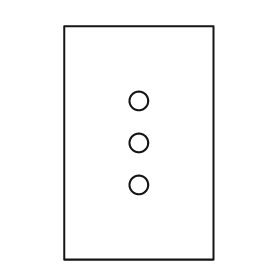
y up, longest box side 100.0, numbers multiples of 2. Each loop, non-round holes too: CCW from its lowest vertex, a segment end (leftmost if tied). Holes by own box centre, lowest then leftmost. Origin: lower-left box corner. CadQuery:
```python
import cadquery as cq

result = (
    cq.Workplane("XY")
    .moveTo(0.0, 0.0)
    .lineTo(64.0, 0.0)
    .lineTo(64.0, 100.0)
    .lineTo(0.0, 100.0)
    .close()
    .moveTo(32.0, 32.0)
    .circle(4.0)
    .moveTo(32.0, 50.0)
    .circle(4.0)
    .moveTo(32.0, 68.0)
    .circle(4.0)
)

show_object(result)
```